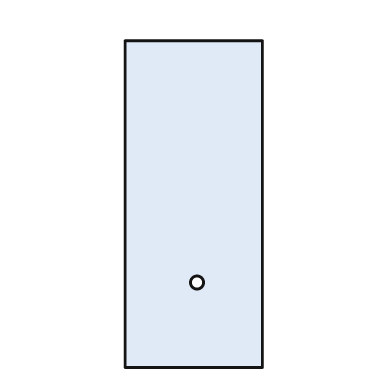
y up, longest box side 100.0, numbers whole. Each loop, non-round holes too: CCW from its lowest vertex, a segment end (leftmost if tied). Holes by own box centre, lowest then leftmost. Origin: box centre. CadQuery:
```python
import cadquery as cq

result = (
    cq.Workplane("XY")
    .moveTo(-21.0, -50.0)
    .lineTo(21.0, -50.0)
    .lineTo(21.0, 50.0)
    .lineTo(-21.0, 50.0)
    .close()
    .moveTo(1.0, -24.0)
    .circle(2.0)
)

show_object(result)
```